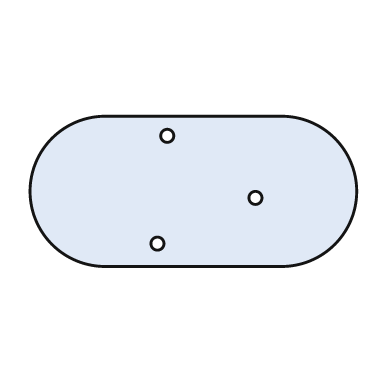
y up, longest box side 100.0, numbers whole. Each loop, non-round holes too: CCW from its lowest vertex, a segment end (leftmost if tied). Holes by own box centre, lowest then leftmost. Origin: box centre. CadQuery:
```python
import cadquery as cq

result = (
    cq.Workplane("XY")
    .moveTo(-27.0, -23.0)
    .lineTo(27.0, -23.0)
    .threePointArc((50.0, 0.0), (27.0, 23.0))
    .lineTo(-27.0, 23.0)
    .threePointArc((-50.0, 0.0), (-27.0, -23.0))
    .close()
    .moveTo(-11.0, -16.0)
    .circle(2.0)
    .moveTo(19.0, -2.0)
    .circle(2.0)
    .moveTo(-8.0, 17.0)
    .circle(2.0)
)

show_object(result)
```